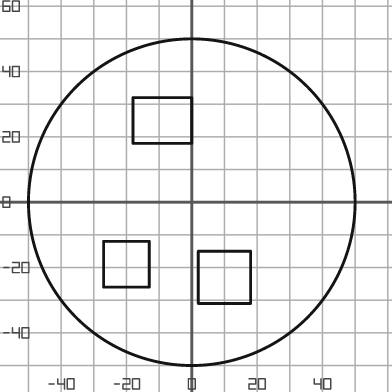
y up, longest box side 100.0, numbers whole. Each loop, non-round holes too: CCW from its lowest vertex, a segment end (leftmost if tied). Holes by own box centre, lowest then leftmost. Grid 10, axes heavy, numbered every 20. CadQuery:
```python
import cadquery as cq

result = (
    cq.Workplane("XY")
    .moveTo(0.0, 0.0)
    .circle(50.0)
    .moveTo(2.0, -31.0)
    .lineTo(18.0, -31.0)
    .lineTo(18.0, -15.0)
    .lineTo(2.0, -15.0)
    .close()
    .moveTo(-27.0, -26.0)
    .lineTo(-13.0, -26.0)
    .lineTo(-13.0, -12.0)
    .lineTo(-27.0, -12.0)
    .close()
    .moveTo(-18.0, 18.0)
    .lineTo(0.0, 18.0)
    .lineTo(0.0, 32.0)
    .lineTo(-18.0, 32.0)
    .close()
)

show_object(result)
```